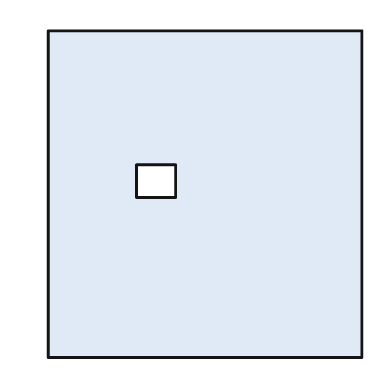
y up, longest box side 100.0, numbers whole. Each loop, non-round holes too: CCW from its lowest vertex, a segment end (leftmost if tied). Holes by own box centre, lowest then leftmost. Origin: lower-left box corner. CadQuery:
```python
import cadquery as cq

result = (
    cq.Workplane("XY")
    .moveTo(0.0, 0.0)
    .lineTo(96.0, 0.0)
    .lineTo(96.0, 100.0)
    .lineTo(0.0, 100.0)
    .close()
    .moveTo(27.0, 49.0)
    .lineTo(39.0, 49.0)
    .lineTo(39.0, 59.0)
    .lineTo(27.0, 59.0)
    .close()
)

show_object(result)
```